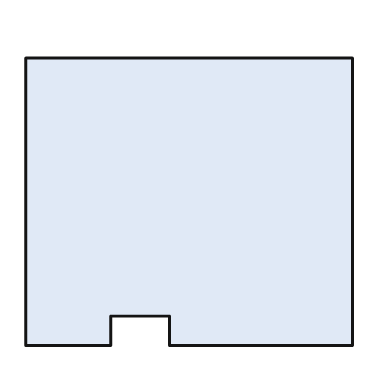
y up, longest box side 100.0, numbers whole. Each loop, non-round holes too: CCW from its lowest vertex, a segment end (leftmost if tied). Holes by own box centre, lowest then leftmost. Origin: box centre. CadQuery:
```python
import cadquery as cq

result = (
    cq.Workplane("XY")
    .moveTo(-50.0, -44.0)
    .lineTo(-24.0, -44.0)
    .lineTo(-24.0, -35.0)
    .lineTo(-6.0, -35.0)
    .lineTo(-6.0, -44.0)
    .lineTo(50.0, -44.0)
    .lineTo(50.0, 44.0)
    .lineTo(-50.0, 44.0)
    .close()
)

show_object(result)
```